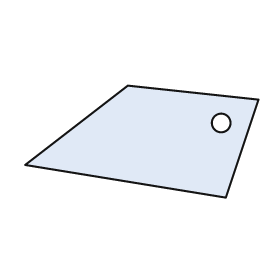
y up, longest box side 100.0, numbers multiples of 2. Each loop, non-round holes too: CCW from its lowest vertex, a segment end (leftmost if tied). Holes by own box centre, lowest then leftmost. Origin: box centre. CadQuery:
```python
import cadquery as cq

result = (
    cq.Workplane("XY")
    .moveTo(36.0, -24.0)
    .lineTo(50.0, 18.0)
    .lineTo(-6.0, 24.0)
    .lineTo(-50.0, -10.0)
    .close()
    .moveTo(34.0, 8.0)
    .circle(4.0)
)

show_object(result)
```